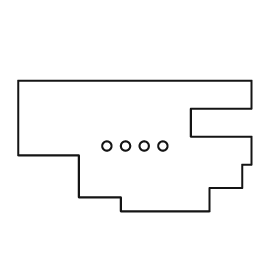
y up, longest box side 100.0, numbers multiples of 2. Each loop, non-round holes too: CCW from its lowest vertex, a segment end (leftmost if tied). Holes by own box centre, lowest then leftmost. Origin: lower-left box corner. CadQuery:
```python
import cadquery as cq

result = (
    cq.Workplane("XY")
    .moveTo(44.0, 0.0)
    .lineTo(82.0, 0.0)
    .lineTo(82.0, 10.0)
    .lineTo(96.0, 10.0)
    .lineTo(96.0, 20.0)
    .lineTo(100.0, 20.0)
    .lineTo(100.0, 32.0)
    .lineTo(74.0, 32.0)
    .lineTo(74.0, 44.0)
    .lineTo(100.0, 44.0)
    .lineTo(100.0, 56.0)
    .lineTo(0.0, 56.0)
    .lineTo(0.0, 24.0)
    .lineTo(26.0, 24.0)
    .lineTo(26.0, 6.0)
    .lineTo(44.0, 6.0)
    .close()
    .moveTo(38.0, 28.0)
    .circle(2.0)
    .moveTo(46.0, 28.0)
    .circle(2.0)
    .moveTo(54.0, 28.0)
    .circle(2.0)
    .moveTo(62.0, 28.0)
    .circle(2.0)
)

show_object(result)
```